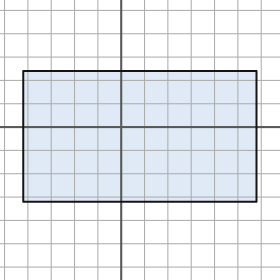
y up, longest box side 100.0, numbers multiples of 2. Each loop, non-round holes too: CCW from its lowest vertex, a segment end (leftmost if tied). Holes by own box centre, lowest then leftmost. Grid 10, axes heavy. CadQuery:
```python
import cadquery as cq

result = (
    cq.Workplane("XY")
    .moveTo(-42.0, -32.0)
    .lineTo(58.0, -32.0)
    .lineTo(58.0, 24.0)
    .lineTo(-42.0, 24.0)
    .close()
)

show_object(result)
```